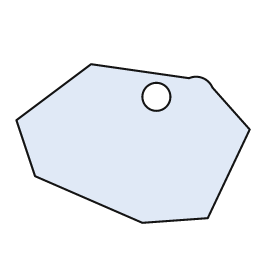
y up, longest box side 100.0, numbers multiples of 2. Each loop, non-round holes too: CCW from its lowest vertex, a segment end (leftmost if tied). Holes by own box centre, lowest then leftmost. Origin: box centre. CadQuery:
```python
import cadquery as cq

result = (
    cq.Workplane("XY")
    .moveTo(4.0, -34.0)
    .lineTo(32.0, -32.0)
    .lineTo(50.0, 6.0)
    .lineTo(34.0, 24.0)
    .threePointArc((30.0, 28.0), (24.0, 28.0))
    .lineTo(-18.0, 34.0)
    .lineTo(-50.0, 10.0)
    .lineTo(-42.0, -14.0)
    .close()
    .moveTo(10.0, 20.0)
    .circle(6.0)
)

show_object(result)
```